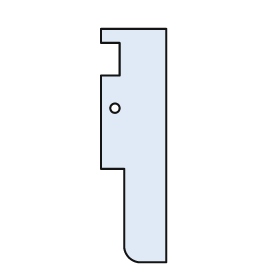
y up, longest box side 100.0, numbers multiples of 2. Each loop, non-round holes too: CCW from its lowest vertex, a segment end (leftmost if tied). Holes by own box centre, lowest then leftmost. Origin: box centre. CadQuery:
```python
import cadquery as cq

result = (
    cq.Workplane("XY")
    .moveTo(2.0, -50.0)
    .lineTo(14.0, -50.0)
    .lineTo(14.0, 50.0)
    .lineTo(-14.0, 50.0)
    .lineTo(-14.0, 44.0)
    .lineTo(-6.0, 44.0)
    .lineTo(-6.0, 30.0)
    .lineTo(-14.0, 30.0)
    .lineTo(-14.0, -10.0)
    .lineTo(-4.0, -10.0)
    .lineTo(-4.0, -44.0)
    .threePointArc((-2.0, -48.0), (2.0, -50.0))
    .close()
    .moveTo(-8.0, 16.0)
    .circle(2.0)
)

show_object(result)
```